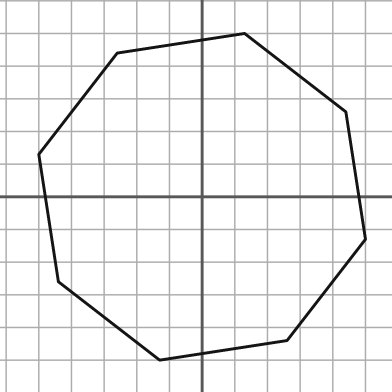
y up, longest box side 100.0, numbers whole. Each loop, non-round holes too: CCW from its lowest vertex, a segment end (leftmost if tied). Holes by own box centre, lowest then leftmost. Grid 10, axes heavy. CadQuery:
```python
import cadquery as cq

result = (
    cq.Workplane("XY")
    .moveTo(-13.0, -50.0)
    .lineTo(26.0, -44.0)
    .lineTo(50.0, -13.0)
    .lineTo(44.0, 26.0)
    .lineTo(13.0, 50.0)
    .lineTo(-26.0, 44.0)
    .lineTo(-50.0, 13.0)
    .lineTo(-44.0, -26.0)
    .close()
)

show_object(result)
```